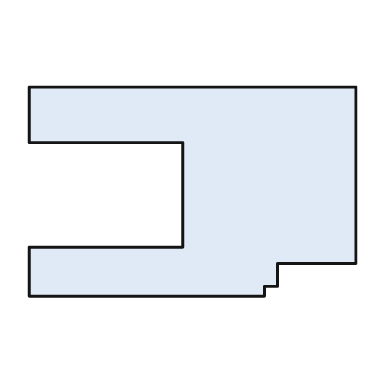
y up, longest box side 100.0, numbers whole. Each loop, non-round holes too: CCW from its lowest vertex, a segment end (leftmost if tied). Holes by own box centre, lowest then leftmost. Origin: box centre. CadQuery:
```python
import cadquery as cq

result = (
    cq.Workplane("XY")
    .moveTo(-50.0, -32.0)
    .lineTo(22.0, -32.0)
    .lineTo(22.0, -29.0)
    .lineTo(26.0, -29.0)
    .lineTo(26.0, -22.0)
    .lineTo(50.0, -22.0)
    .lineTo(50.0, 32.0)
    .lineTo(-50.0, 32.0)
    .lineTo(-50.0, 15.0)
    .lineTo(-3.0, 15.0)
    .lineTo(-3.0, -17.0)
    .lineTo(-50.0, -17.0)
    .close()
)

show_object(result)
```